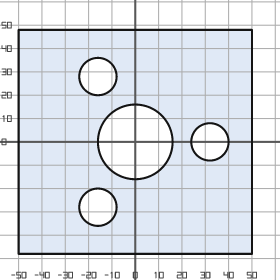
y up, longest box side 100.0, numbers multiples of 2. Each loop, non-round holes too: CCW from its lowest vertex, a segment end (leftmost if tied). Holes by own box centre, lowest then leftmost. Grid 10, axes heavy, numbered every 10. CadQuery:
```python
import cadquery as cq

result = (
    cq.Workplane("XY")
    .moveTo(-50.0, -48.0)
    .lineTo(50.0, -48.0)
    .lineTo(50.0, 48.0)
    .lineTo(-50.0, 48.0)
    .close()
    .moveTo(-16.0, -28.0)
    .circle(8.0)
    .moveTo(0.0, 0.0)
    .circle(16.0)
    .moveTo(32.0, 0.0)
    .circle(8.0)
    .moveTo(-16.0, 28.0)
    .circle(8.0)
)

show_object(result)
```